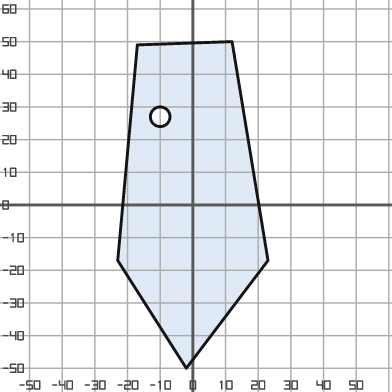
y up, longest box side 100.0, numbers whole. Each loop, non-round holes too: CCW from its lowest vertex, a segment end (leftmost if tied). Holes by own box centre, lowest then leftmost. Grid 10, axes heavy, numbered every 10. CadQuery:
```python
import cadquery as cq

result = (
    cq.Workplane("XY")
    .moveTo(-2.0, -50.0)
    .lineTo(23.0, -17.0)
    .lineTo(12.0, 50.0)
    .lineTo(-17.0, 49.0)
    .lineTo(-23.0, -17.0)
    .close()
    .moveTo(-10.0, 27.0)
    .circle(3.0)
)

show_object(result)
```